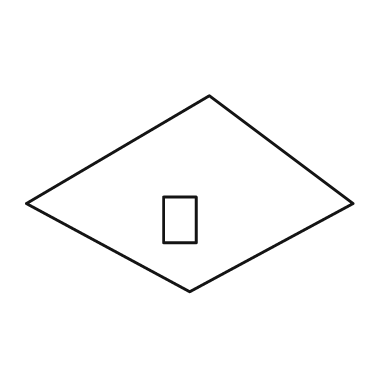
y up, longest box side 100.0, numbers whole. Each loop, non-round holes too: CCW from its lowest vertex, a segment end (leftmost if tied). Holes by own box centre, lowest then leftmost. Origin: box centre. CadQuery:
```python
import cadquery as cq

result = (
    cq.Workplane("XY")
    .moveTo(0.0, -30.0)
    .lineTo(50.0, -3.0)
    .lineTo(6.0, 30.0)
    .lineTo(-50.0, -3.0)
    .close()
    .moveTo(-8.0, -15.0)
    .lineTo(2.0, -15.0)
    .lineTo(2.0, -1.0)
    .lineTo(-8.0, -1.0)
    .close()
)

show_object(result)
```